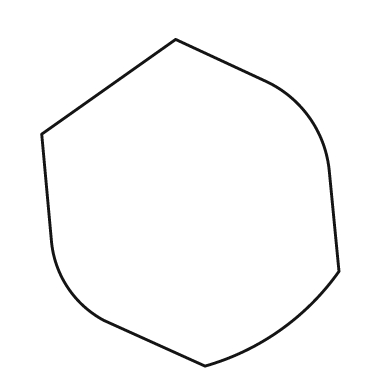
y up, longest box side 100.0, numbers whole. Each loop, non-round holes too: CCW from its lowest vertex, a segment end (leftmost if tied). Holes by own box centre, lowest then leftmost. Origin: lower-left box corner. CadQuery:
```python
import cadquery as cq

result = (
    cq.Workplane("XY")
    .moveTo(50.0, 0.0)
    .threePointArc((73.0, 11.0), (91.0, 29.0))
    .lineTo(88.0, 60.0)
    .threePointArc((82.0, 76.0), (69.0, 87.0))
    .lineTo(41.0, 100.0)
    .lineTo(0.0, 71.0)
    .lineTo(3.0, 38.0)
    .threePointArc((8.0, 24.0), (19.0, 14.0))
    .close()
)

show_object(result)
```